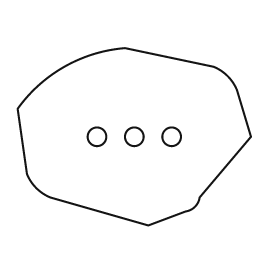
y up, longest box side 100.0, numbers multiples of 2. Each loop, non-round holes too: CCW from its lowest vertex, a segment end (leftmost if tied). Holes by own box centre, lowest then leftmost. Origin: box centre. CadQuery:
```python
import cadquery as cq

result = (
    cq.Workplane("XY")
    .moveTo(6.0, -38.0)
    .lineTo(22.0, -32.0)
    .threePointArc((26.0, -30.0), (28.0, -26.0))
    .lineTo(50.0, 0.0)
    .lineTo(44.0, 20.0)
    .threePointArc((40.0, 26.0), (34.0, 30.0))
    .lineTo(-4.0, 38.0)
    .threePointArc((-30.0, 30.0), (-50.0, 12.0))
    .lineTo(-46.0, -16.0)
    .threePointArc((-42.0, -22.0), (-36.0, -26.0))
    .close()
    .moveTo(-16.0, 0.0)
    .circle(4.0)
    .moveTo(0.0, 0.0)
    .circle(4.0)
    .moveTo(16.0, 0.0)
    .circle(4.0)
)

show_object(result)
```